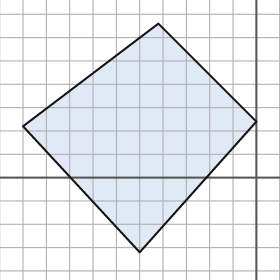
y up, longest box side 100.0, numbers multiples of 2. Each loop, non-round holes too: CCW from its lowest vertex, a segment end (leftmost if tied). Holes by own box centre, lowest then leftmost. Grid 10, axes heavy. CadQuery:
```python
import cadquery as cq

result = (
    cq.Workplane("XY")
    .moveTo(-50.0, -32.0)
    .lineTo(0.0, 24.0)
    .lineTo(-42.0, 66.0)
    .lineTo(-100.0, 22.0)
    .close()
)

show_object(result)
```